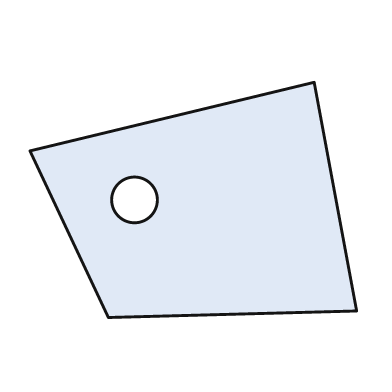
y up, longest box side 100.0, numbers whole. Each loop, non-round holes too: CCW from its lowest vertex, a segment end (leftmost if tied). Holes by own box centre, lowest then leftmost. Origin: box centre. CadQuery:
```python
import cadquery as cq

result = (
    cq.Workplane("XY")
    .moveTo(-26.0, -36.0)
    .lineTo(50.0, -34.0)
    .lineTo(37.0, 36.0)
    .lineTo(-50.0, 15.0)
    .close()
    .moveTo(-18.0, 0.0)
    .circle(7.0)
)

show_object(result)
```